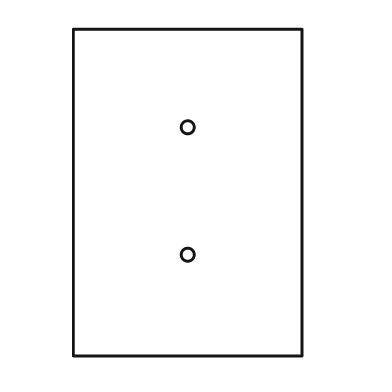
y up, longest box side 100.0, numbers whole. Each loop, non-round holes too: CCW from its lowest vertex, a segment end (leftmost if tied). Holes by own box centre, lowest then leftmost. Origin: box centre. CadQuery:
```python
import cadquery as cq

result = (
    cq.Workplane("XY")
    .moveTo(-35.0, -50.0)
    .lineTo(35.0, -50.0)
    .lineTo(35.0, 50.0)
    .lineTo(-35.0, 50.0)
    .close()
    .moveTo(0.0, -19.0)
    .circle(2.0)
    .moveTo(0.0, 20.0)
    .circle(2.0)
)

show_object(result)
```